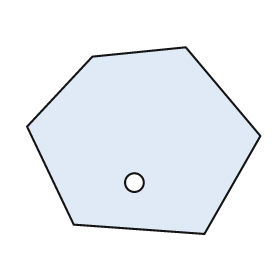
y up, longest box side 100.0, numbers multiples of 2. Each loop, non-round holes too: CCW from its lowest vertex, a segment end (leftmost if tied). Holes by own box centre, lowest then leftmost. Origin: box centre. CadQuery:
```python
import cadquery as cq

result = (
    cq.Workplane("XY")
    .moveTo(26.0, -40.0)
    .lineTo(50.0, 2.0)
    .lineTo(18.0, 40.0)
    .lineTo(-22.0, 36.0)
    .lineTo(-50.0, 6.0)
    .lineTo(-30.0, -36.0)
    .close()
    .moveTo(-4.0, -18.0)
    .circle(4.0)
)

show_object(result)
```